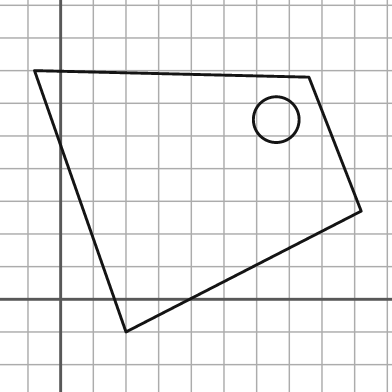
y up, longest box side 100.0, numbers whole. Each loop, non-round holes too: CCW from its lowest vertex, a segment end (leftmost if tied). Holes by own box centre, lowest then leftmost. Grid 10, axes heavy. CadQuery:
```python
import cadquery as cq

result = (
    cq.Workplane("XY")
    .moveTo(20.0, -10.0)
    .lineTo(92.0, 27.0)
    .lineTo(76.0, 68.0)
    .lineTo(-8.0, 70.0)
    .close()
    .moveTo(66.0, 55.0)
    .circle(7.0)
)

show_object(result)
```